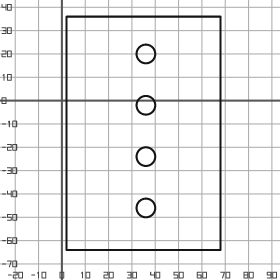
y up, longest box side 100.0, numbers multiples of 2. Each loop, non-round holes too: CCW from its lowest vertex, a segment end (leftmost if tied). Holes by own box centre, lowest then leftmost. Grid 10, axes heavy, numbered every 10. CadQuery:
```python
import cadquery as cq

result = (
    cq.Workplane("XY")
    .moveTo(2.0, -64.0)
    .lineTo(68.0, -64.0)
    .lineTo(68.0, 36.0)
    .lineTo(2.0, 36.0)
    .close()
    .moveTo(36.0, -46.0)
    .circle(4.0)
    .moveTo(36.0, -24.0)
    .circle(4.0)
    .moveTo(36.0, -2.0)
    .circle(4.0)
    .moveTo(36.0, 20.0)
    .circle(4.0)
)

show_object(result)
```